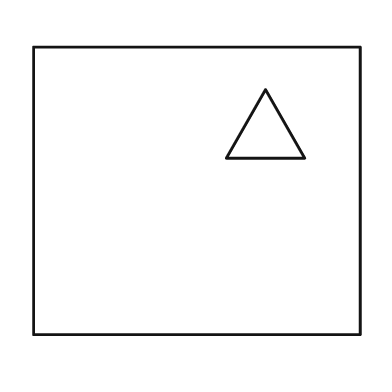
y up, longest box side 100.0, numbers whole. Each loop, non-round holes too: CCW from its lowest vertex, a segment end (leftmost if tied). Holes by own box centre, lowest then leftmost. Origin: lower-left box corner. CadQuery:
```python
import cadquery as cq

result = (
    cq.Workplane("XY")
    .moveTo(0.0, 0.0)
    .lineTo(100.0, 0.0)
    .lineTo(100.0, 88.0)
    .lineTo(0.0, 88.0)
    .close()
    .moveTo(59.0, 54.0)
    .lineTo(83.0, 54.0)
    .lineTo(71.0, 75.0)
    .close()
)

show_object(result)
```